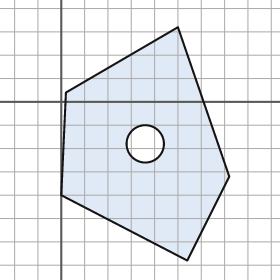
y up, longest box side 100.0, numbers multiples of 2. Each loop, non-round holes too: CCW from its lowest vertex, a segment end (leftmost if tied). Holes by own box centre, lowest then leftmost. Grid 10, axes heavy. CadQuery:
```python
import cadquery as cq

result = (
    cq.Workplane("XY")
    .moveTo(54.0, -68.0)
    .lineTo(72.0, -32.0)
    .lineTo(50.0, 32.0)
    .lineTo(2.0, 4.0)
    .lineTo(0.0, -40.0)
    .close()
    .moveTo(36.0, -18.0)
    .circle(8.0)
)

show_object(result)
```